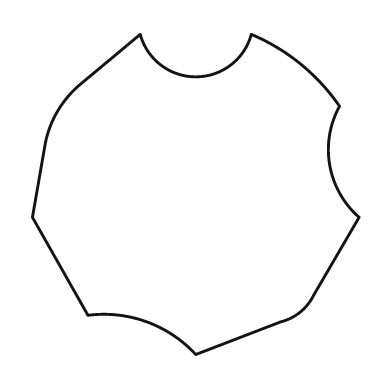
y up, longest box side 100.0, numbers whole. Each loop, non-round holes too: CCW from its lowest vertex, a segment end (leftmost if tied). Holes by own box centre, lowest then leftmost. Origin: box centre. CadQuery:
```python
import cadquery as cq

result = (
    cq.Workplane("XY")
    .moveTo(0.0, -49.0)
    .lineTo(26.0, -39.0)
    .threePointArc((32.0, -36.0), (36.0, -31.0))
    .lineTo(50.0, -7.0)
    .threePointArc((41.0, 9.0), (44.0, 27.0))
    .threePointArc((32.0, 40.0), (17.0, 49.0))
    .threePointArc((0.0, 36.0), (-17.0, 49.0))
    .lineTo(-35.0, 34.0)
    .threePointArc((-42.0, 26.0), (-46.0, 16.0))
    .lineTo(-50.0, -7.0)
    .lineTo(-33.0, -37.0)
    .threePointArc((-15.0, -39.0), (0.0, -49.0))
    .close()
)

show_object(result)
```